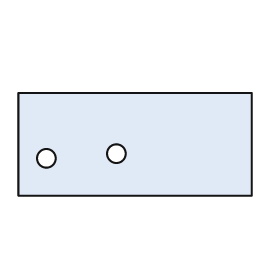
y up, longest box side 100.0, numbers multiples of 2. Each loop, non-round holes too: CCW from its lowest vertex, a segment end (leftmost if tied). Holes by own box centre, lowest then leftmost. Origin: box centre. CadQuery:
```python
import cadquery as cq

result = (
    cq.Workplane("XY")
    .moveTo(-50.0, -22.0)
    .lineTo(50.0, -22.0)
    .lineTo(50.0, 22.0)
    .lineTo(-50.0, 22.0)
    .close()
    .moveTo(-38.0, -6.0)
    .circle(4.0)
    .moveTo(-8.0, -4.0)
    .circle(4.0)
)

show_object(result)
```